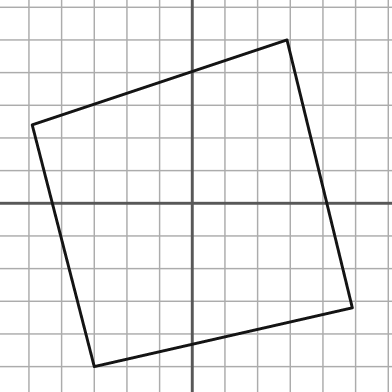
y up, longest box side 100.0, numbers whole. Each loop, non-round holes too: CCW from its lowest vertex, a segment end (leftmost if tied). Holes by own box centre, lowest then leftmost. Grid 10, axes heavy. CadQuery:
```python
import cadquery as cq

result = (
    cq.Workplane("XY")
    .moveTo(-30.0, -50.0)
    .lineTo(49.0, -32.0)
    .lineTo(29.0, 50.0)
    .lineTo(-49.0, 24.0)
    .close()
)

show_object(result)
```